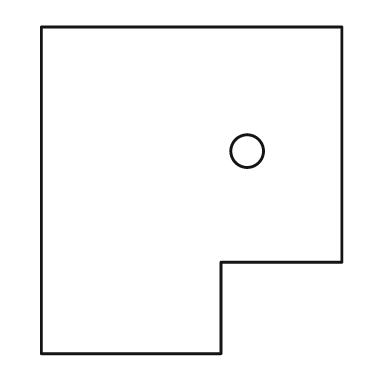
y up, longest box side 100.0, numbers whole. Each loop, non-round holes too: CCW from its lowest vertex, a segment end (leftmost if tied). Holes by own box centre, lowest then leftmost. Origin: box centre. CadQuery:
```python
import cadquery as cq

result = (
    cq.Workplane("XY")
    .moveTo(-46.0, -50.0)
    .lineTo(9.0, -50.0)
    .lineTo(9.0, -22.0)
    .lineTo(46.0, -22.0)
    .lineTo(46.0, 50.0)
    .lineTo(-46.0, 50.0)
    .close()
    .moveTo(17.0, 12.0)
    .circle(5.0)
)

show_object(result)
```